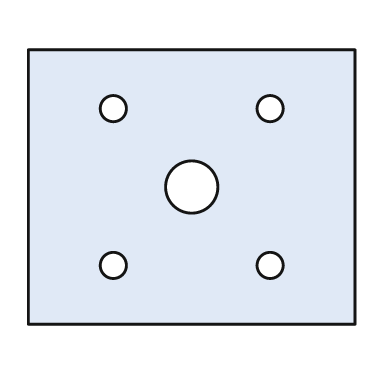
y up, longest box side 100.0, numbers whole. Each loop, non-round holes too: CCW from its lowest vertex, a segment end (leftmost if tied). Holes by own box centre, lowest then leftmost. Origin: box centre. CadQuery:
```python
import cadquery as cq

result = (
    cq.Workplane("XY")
    .moveTo(-50.0, -42.0)
    .lineTo(50.0, -42.0)
    .lineTo(50.0, 42.0)
    .lineTo(-50.0, 42.0)
    .close()
    .moveTo(-24.0, -24.0)
    .circle(4.0)
    .moveTo(24.0, -24.0)
    .circle(4.0)
    .moveTo(0.0, 0.0)
    .circle(8.0)
    .moveTo(-24.0, 24.0)
    .circle(4.0)
    .moveTo(24.0, 24.0)
    .circle(4.0)
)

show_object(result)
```